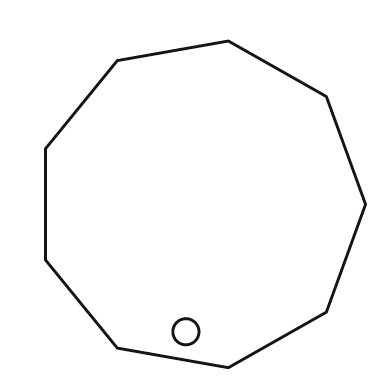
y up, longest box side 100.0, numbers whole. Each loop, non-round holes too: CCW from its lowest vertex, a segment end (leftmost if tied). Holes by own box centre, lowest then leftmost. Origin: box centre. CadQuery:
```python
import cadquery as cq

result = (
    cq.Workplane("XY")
    .moveTo(7.0, -50.0)
    .lineTo(37.0, -33.0)
    .lineTo(49.0, 0.0)
    .lineTo(37.0, 33.0)
    .lineTo(7.0, 50.0)
    .lineTo(-27.0, 44.0)
    .lineTo(-49.0, 17.0)
    .lineTo(-49.0, -17.0)
    .lineTo(-27.0, -44.0)
    .close()
    .moveTo(-6.0, -39.0)
    .circle(4.0)
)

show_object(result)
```